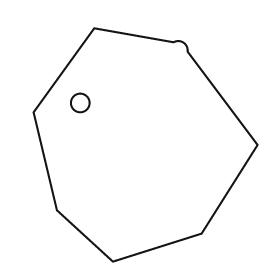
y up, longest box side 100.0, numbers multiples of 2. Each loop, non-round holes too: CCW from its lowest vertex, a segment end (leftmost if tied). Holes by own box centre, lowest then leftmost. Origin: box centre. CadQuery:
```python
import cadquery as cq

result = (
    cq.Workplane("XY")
    .moveTo(-14.0, -50.0)
    .lineTo(24.0, -38.0)
    .lineTo(48.0, 0.0)
    .lineTo(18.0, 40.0)
    .threePointArc((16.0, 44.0), (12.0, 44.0))
    .lineTo(-22.0, 50.0)
    .lineTo(-48.0, 14.0)
    .lineTo(-38.0, -28.0)
    .close()
    .moveTo(-28.0, 18.0)
    .circle(4.0)
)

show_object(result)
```